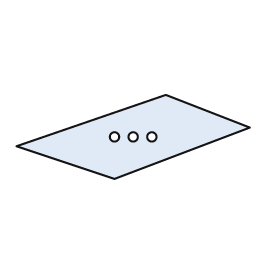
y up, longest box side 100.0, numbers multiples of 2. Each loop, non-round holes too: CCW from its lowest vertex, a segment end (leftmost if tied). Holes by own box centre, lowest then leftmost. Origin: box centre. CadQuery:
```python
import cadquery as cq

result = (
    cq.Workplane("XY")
    .moveTo(-8.0, -18.0)
    .lineTo(50.0, 4.0)
    .lineTo(14.0, 18.0)
    .lineTo(-50.0, -4.0)
    .close()
    .moveTo(-8.0, 0.0)
    .circle(2.0)
    .moveTo(0.0, 0.0)
    .circle(2.0)
    .moveTo(8.0, 0.0)
    .circle(2.0)
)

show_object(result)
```